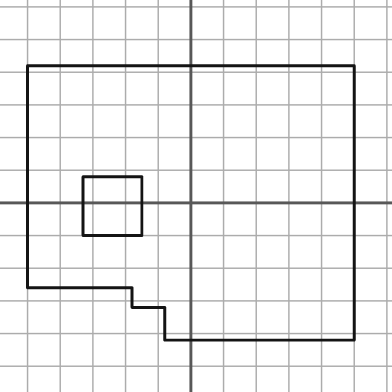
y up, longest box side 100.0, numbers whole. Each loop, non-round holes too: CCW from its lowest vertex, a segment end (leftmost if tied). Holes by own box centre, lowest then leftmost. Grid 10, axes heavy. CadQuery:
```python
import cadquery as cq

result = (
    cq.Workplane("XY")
    .moveTo(-8.0, -42.0)
    .lineTo(50.0, -42.0)
    .lineTo(50.0, 42.0)
    .lineTo(-50.0, 42.0)
    .lineTo(-50.0, -26.0)
    .lineTo(-18.0, -26.0)
    .lineTo(-18.0, -32.0)
    .lineTo(-8.0, -32.0)
    .close()
    .moveTo(-33.0, -10.0)
    .lineTo(-15.0, -10.0)
    .lineTo(-15.0, 8.0)
    .lineTo(-33.0, 8.0)
    .close()
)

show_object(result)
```